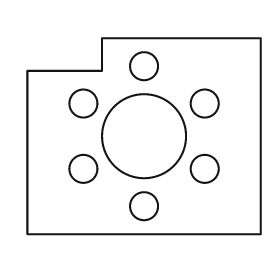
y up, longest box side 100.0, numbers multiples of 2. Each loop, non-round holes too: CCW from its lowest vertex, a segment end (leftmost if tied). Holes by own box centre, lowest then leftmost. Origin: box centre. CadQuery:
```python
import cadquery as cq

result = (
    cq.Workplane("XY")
    .moveTo(-50.0, -42.0)
    .lineTo(50.0, -42.0)
    .lineTo(50.0, 42.0)
    .lineTo(-18.0, 42.0)
    .lineTo(-18.0, 28.0)
    .lineTo(-50.0, 28.0)
    .close()
    .moveTo(0.0, -30.0)
    .circle(6.0)
    .moveTo(-26.0, -14.0)
    .circle(6.0)
    .moveTo(26.0, -14.0)
    .circle(6.0)
    .moveTo(0.0, 0.0)
    .circle(18.0)
    .moveTo(-26.0, 14.0)
    .circle(6.0)
    .moveTo(26.0, 14.0)
    .circle(6.0)
    .moveTo(0.0, 30.0)
    .circle(6.0)
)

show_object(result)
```